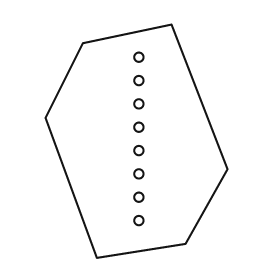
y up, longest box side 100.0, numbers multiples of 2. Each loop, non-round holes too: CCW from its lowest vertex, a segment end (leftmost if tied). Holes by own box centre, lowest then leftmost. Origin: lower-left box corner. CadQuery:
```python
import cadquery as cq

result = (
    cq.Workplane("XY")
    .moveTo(22.0, 0.0)
    .lineTo(60.0, 6.0)
    .lineTo(78.0, 38.0)
    .lineTo(54.0, 100.0)
    .lineTo(16.0, 92.0)
    .lineTo(0.0, 60.0)
    .close()
    .moveTo(40.0, 16.0)
    .circle(2.0)
    .moveTo(40.0, 26.0)
    .circle(2.0)
    .moveTo(40.0, 36.0)
    .circle(2.0)
    .moveTo(40.0, 46.0)
    .circle(2.0)
    .moveTo(40.0, 56.0)
    .circle(2.0)
    .moveTo(40.0, 66.0)
    .circle(2.0)
    .moveTo(40.0, 76.0)
    .circle(2.0)
    .moveTo(40.0, 86.0)
    .circle(2.0)
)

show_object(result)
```